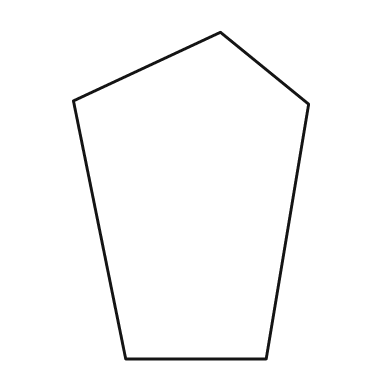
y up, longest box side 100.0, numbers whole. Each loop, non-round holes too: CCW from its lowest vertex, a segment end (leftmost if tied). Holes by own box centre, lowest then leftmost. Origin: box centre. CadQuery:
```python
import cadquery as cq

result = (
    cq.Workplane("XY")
    .moveTo(-20.0, -50.0)
    .lineTo(23.0, -50.0)
    .lineTo(36.0, 28.0)
    .lineTo(9.0, 50.0)
    .lineTo(-36.0, 29.0)
    .close()
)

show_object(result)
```